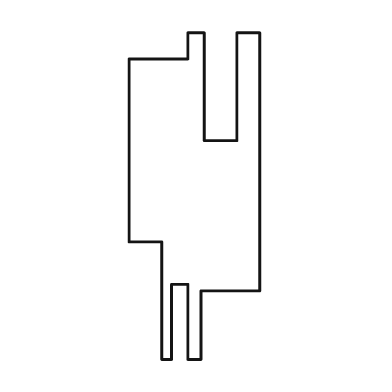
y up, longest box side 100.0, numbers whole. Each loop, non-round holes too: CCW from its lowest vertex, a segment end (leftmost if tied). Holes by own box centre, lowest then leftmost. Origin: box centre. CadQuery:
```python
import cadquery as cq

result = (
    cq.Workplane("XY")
    .moveTo(-10.0, -50.0)
    .lineTo(-7.0, -50.0)
    .lineTo(-7.0, -27.0)
    .lineTo(-2.0, -27.0)
    .lineTo(-2.0, -50.0)
    .lineTo(2.0, -50.0)
    .lineTo(2.0, -29.0)
    .lineTo(20.0, -29.0)
    .lineTo(20.0, 50.0)
    .lineTo(13.0, 50.0)
    .lineTo(13.0, 17.0)
    .lineTo(3.0, 17.0)
    .lineTo(3.0, 50.0)
    .lineTo(-2.0, 50.0)
    .lineTo(-2.0, 42.0)
    .lineTo(-20.0, 42.0)
    .lineTo(-20.0, -14.0)
    .lineTo(-10.0, -14.0)
    .close()
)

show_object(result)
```